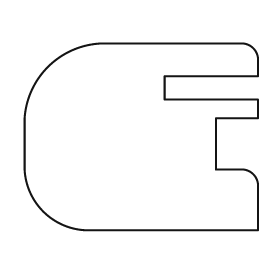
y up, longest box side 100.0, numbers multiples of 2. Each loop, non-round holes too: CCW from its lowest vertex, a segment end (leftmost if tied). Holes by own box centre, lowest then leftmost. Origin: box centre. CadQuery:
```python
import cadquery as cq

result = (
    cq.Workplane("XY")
    .moveTo(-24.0, -40.0)
    .lineTo(50.0, -40.0)
    .lineTo(50.0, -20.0)
    .threePointArc((48.0, -16.0), (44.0, -14.0))
    .lineTo(32.0, -14.0)
    .lineTo(32.0, 8.0)
    .lineTo(50.0, 8.0)
    .lineTo(50.0, 16.0)
    .lineTo(10.0, 16.0)
    .lineTo(10.0, 26.0)
    .lineTo(50.0, 26.0)
    .lineTo(50.0, 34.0)
    .threePointArc((48.0, 38.0), (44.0, 40.0))
    .lineTo(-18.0, 40.0)
    .threePointArc((-40.0, 30.0), (-50.0, 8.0))
    .lineTo(-50.0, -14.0)
    .threePointArc((-42.0, -32.0), (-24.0, -40.0))
    .close()
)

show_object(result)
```